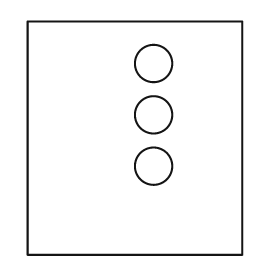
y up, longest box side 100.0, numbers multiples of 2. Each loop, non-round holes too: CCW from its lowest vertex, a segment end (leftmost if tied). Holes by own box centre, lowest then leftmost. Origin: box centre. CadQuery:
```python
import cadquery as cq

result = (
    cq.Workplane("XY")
    .moveTo(-46.0, -50.0)
    .lineTo(46.0, -50.0)
    .lineTo(46.0, 50.0)
    .lineTo(-46.0, 50.0)
    .close()
    .moveTo(8.0, -12.0)
    .circle(8.0)
    .moveTo(8.0, 10.0)
    .circle(8.0)
    .moveTo(8.0, 32.0)
    .circle(8.0)
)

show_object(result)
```